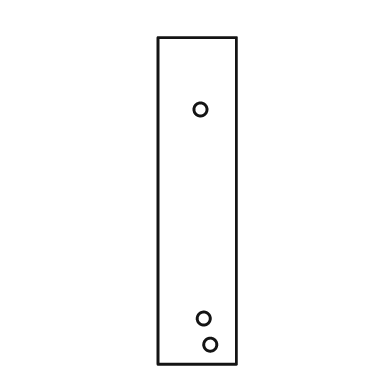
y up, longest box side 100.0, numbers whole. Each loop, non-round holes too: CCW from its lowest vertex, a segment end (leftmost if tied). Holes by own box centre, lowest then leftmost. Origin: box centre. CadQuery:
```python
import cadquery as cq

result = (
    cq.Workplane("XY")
    .moveTo(-12.0, -50.0)
    .lineTo(12.0, -50.0)
    .lineTo(12.0, 50.0)
    .lineTo(-12.0, 50.0)
    .close()
    .moveTo(4.0, -44.0)
    .circle(2.0)
    .moveTo(2.0, -36.0)
    .circle(2.0)
    .moveTo(1.0, 28.0)
    .circle(2.0)
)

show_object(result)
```